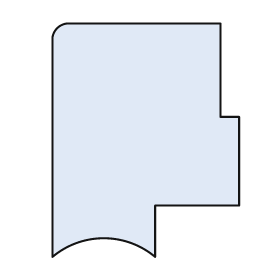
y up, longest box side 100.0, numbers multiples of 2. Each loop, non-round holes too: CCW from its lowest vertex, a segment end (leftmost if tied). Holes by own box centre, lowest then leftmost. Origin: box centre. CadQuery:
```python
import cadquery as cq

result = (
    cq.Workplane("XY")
    .moveTo(-40.0, -50.0)
    .threePointArc((-18.0, -42.0), (4.0, -50.0))
    .lineTo(4.0, -28.0)
    .lineTo(40.0, -28.0)
    .lineTo(40.0, 10.0)
    .lineTo(32.0, 10.0)
    .lineTo(32.0, 50.0)
    .lineTo(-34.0, 50.0)
    .threePointArc((-38.0, 48.0), (-40.0, 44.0))
    .close()
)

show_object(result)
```